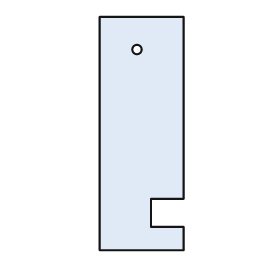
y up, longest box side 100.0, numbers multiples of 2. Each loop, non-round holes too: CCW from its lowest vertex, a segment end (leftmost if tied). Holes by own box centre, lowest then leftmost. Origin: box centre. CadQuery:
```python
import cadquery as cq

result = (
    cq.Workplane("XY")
    .moveTo(-18.0, -50.0)
    .lineTo(18.0, -50.0)
    .lineTo(18.0, -40.0)
    .lineTo(4.0, -40.0)
    .lineTo(4.0, -28.0)
    .lineTo(18.0, -28.0)
    .lineTo(18.0, 50.0)
    .lineTo(-18.0, 50.0)
    .close()
    .moveTo(-2.0, 36.0)
    .circle(2.0)
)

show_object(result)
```